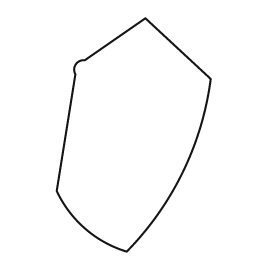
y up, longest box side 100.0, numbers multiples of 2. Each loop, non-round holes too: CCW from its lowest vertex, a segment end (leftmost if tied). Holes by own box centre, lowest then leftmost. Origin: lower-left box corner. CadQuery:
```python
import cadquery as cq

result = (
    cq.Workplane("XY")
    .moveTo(30.0, 0.0)
    .threePointArc((54.0, 34.0), (66.0, 74.0))
    .lineTo(38.0, 100.0)
    .lineTo(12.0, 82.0)
    .threePointArc((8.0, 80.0), (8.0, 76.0))
    .lineTo(0.0, 26.0)
    .threePointArc((12.0, 10.0), (30.0, 0.0))
    .close()
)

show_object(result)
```